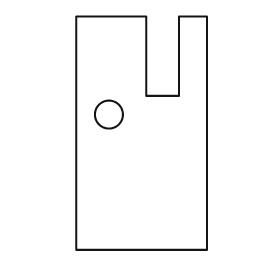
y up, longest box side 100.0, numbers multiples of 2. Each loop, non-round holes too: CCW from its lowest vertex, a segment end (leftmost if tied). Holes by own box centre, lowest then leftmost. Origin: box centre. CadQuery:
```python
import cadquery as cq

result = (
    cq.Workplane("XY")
    .moveTo(-28.0, -50.0)
    .lineTo(28.0, -50.0)
    .lineTo(28.0, 50.0)
    .lineTo(16.0, 50.0)
    .lineTo(16.0, 16.0)
    .lineTo(2.0, 16.0)
    .lineTo(2.0, 50.0)
    .lineTo(-28.0, 50.0)
    .close()
    .moveTo(-14.0, 8.0)
    .circle(6.0)
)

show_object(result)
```